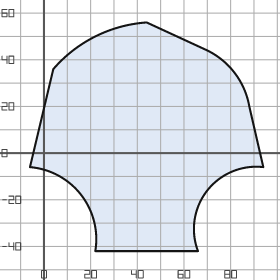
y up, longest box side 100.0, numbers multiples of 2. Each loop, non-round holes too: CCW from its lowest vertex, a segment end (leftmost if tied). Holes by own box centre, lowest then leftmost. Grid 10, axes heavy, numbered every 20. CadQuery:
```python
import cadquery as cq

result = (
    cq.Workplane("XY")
    .moveTo(22.0, -42.0)
    .lineTo(66.0, -42.0)
    .threePointArc((70.0, -16.0), (94.0, -6.0))
    .lineTo(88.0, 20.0)
    .threePointArc((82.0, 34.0), (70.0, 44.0))
    .lineTo(44.0, 56.0)
    .threePointArc((22.0, 50.0), (4.0, 36.0))
    .lineTo(-6.0, -6.0)
    .threePointArc((16.0, -18.0), (22.0, -42.0))
    .close()
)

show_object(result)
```